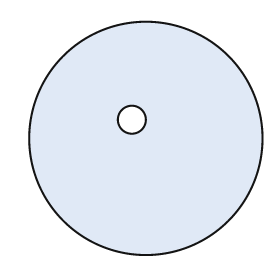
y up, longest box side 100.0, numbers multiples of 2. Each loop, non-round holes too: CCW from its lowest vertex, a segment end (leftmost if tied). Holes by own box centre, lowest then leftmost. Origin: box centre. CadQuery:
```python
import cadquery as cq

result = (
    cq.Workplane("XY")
    .moveTo(0.0, 0.0)
    .circle(50.0)
    .moveTo(-6.0, 8.0)
    .circle(6.0)
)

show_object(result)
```